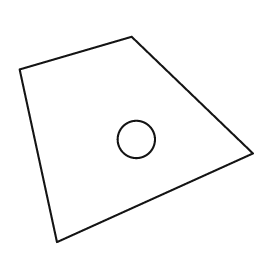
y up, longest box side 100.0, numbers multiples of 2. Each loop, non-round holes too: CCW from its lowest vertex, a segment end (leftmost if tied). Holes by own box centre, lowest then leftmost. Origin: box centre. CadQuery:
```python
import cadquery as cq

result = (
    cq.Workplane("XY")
    .moveTo(-34.0, -44.0)
    .lineTo(50.0, -6.0)
    .lineTo(-2.0, 44.0)
    .lineTo(-50.0, 30.0)
    .close()
    .moveTo(0.0, 0.0)
    .circle(8.0)
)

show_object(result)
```